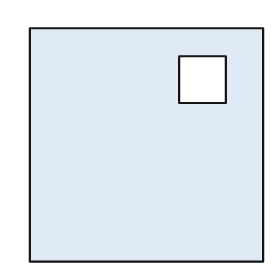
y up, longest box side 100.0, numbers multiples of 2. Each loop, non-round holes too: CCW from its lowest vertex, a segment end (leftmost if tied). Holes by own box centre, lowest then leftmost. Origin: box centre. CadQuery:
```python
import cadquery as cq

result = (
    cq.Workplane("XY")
    .moveTo(-50.0, -50.0)
    .lineTo(50.0, -50.0)
    .lineTo(50.0, 50.0)
    .lineTo(-50.0, 50.0)
    .close()
    .moveTo(14.0, 18.0)
    .lineTo(34.0, 18.0)
    .lineTo(34.0, 38.0)
    .lineTo(14.0, 38.0)
    .close()
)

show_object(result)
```